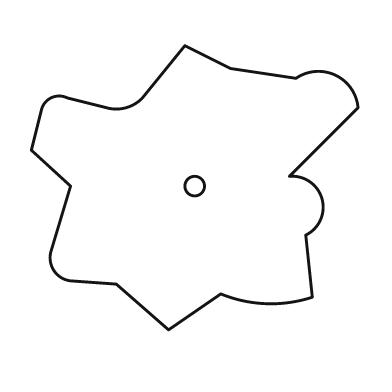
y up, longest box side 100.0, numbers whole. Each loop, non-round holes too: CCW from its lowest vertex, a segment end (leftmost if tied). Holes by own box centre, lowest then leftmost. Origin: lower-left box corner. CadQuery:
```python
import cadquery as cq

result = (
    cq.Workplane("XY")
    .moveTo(42.0, 0.0)
    .lineTo(58.0, 11.0)
    .threePointArc((72.0, 8.0), (86.0, 10.0))
    .lineTo(84.0, 29.0)
    .threePointArc((89.0, 40.0), (79.0, 47.0))
    .lineTo(100.0, 68.0)
    .threePointArc((93.0, 78.0), (81.0, 77.0))
    .lineTo(61.0, 80.0)
    .lineTo(47.0, 87.0)
    .lineTo(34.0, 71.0)
    .threePointArc((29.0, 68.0), (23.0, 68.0))
    .lineTo(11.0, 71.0)
    .threePointArc((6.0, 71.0), (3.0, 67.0))
    .lineTo(0.0, 55.0)
    .lineTo(12.0, 44.0)
    .lineTo(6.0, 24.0)
    .threePointArc((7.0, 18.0), (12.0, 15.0))
    .lineTo(26.0, 14.0)
    .close()
    .moveTo(50.0, 44.0)
    .circle(3.0)
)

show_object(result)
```